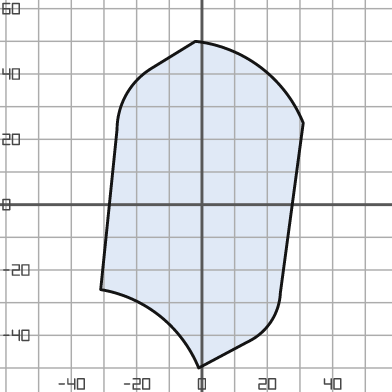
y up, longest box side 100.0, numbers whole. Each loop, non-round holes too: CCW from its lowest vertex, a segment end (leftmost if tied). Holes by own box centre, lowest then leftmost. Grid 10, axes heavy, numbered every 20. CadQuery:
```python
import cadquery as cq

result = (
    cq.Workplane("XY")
    .moveTo(-1.0, -50.0)
    .lineTo(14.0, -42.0)
    .threePointArc((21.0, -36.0), (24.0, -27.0))
    .lineTo(31.0, 25.0)
    .threePointArc((18.0, 42.0), (-2.0, 50.0))
    .lineTo(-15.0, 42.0)
    .threePointArc((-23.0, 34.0), (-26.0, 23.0))
    .lineTo(-31.0, -26.0)
    .threePointArc((-13.0, -34.0), (-1.0, -50.0))
    .close()
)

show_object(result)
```